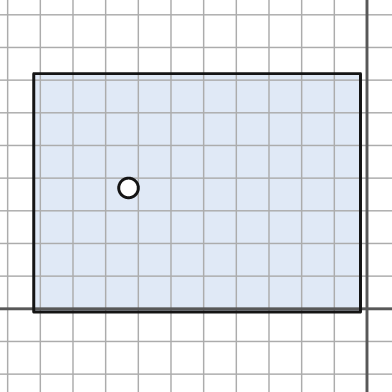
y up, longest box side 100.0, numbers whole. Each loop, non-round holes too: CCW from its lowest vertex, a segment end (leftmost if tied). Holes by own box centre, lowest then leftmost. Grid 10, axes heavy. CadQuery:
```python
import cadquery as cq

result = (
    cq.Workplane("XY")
    .moveTo(-102.0, -1.0)
    .lineTo(-2.0, -1.0)
    .lineTo(-2.0, 72.0)
    .lineTo(-102.0, 72.0)
    .close()
    .moveTo(-73.0, 37.0)
    .circle(3.0)
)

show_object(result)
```